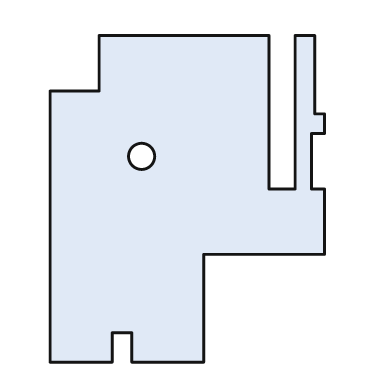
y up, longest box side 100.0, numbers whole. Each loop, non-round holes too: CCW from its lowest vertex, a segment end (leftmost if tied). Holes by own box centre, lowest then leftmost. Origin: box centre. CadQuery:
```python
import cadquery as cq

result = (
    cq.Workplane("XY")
    .moveTo(-42.0, -50.0)
    .lineTo(-23.0, -50.0)
    .lineTo(-23.0, -41.0)
    .lineTo(-17.0, -41.0)
    .lineTo(-17.0, -50.0)
    .lineTo(5.0, -50.0)
    .lineTo(5.0, -17.0)
    .lineTo(42.0, -17.0)
    .lineTo(42.0, 3.0)
    .lineTo(38.0, 3.0)
    .lineTo(38.0, 20.0)
    .lineTo(42.0, 20.0)
    .lineTo(42.0, 26.0)
    .lineTo(39.0, 26.0)
    .lineTo(39.0, 50.0)
    .lineTo(33.0, 50.0)
    .lineTo(33.0, 3.0)
    .lineTo(25.0, 3.0)
    .lineTo(25.0, 50.0)
    .lineTo(-27.0, 50.0)
    .lineTo(-27.0, 33.0)
    .lineTo(-42.0, 33.0)
    .close()
    .moveTo(-14.0, 13.0)
    .circle(4.0)
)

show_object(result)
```